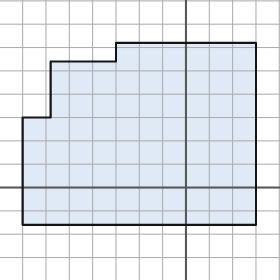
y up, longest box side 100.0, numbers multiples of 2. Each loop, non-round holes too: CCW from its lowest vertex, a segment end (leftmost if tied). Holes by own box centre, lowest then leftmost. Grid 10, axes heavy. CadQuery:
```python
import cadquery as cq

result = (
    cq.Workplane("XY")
    .moveTo(-70.0, -16.0)
    .lineTo(30.0, -16.0)
    .lineTo(30.0, 62.0)
    .lineTo(-30.0, 62.0)
    .lineTo(-30.0, 54.0)
    .lineTo(-58.0, 54.0)
    .lineTo(-58.0, 30.0)
    .lineTo(-70.0, 30.0)
    .close()
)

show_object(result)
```